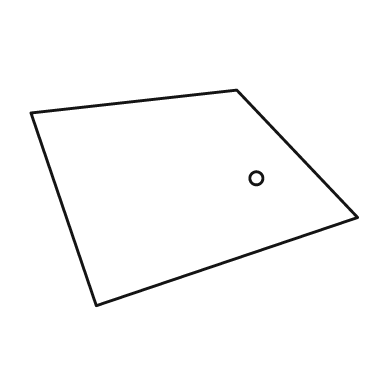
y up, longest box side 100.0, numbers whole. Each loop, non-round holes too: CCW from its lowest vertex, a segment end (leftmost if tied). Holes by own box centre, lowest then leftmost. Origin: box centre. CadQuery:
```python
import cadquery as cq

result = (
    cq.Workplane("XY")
    .moveTo(-30.0, -33.0)
    .lineTo(50.0, -6.0)
    .lineTo(13.0, 33.0)
    .lineTo(-50.0, 26.0)
    .close()
    .moveTo(19.0, 6.0)
    .circle(2.0)
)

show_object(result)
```